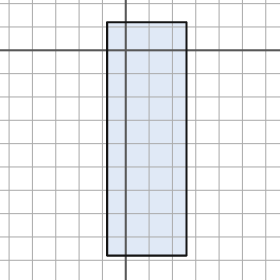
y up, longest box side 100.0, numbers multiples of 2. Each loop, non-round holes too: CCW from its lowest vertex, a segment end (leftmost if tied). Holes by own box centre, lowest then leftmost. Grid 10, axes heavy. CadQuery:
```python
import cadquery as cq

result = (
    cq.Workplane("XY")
    .moveTo(-8.0, -88.0)
    .lineTo(26.0, -88.0)
    .lineTo(26.0, 12.0)
    .lineTo(-8.0, 12.0)
    .close()
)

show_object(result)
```